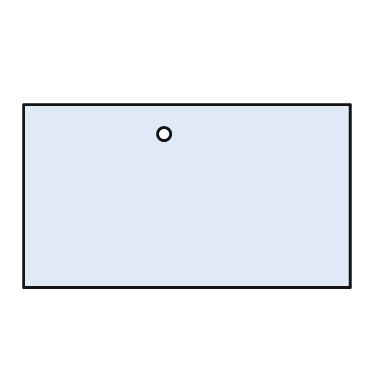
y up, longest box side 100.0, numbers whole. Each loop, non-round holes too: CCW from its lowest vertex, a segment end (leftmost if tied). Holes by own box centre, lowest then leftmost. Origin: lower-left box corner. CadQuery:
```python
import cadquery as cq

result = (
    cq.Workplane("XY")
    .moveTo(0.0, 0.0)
    .lineTo(100.0, 0.0)
    .lineTo(100.0, 56.0)
    .lineTo(0.0, 56.0)
    .close()
    .moveTo(43.0, 47.0)
    .circle(2.0)
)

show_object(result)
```